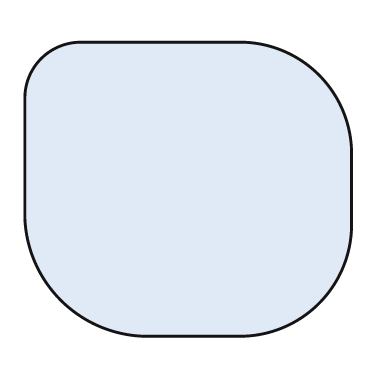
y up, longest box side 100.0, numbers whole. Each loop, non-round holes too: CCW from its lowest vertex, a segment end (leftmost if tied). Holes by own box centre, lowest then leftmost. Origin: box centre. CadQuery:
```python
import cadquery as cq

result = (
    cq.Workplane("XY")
    .moveTo(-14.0, -45.0)
    .lineTo(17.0, -45.0)
    .threePointArc((40.0, -35.0), (50.0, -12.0))
    .lineTo(50.0, 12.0)
    .threePointArc((40.0, 35.0), (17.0, 45.0))
    .lineTo(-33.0, 45.0)
    .threePointArc((-45.0, 40.0), (-50.0, 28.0))
    .lineTo(-50.0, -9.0)
    .threePointArc((-39.0, -34.0), (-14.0, -45.0))
    .close()
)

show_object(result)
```